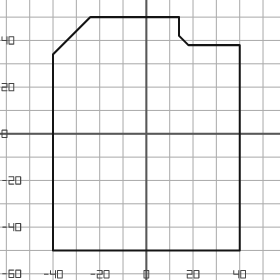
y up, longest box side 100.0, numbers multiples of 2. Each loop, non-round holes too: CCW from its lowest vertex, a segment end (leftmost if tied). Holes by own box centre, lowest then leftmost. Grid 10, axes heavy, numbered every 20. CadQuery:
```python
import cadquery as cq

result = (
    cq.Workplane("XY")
    .moveTo(-40.0, -50.0)
    .lineTo(40.0, -50.0)
    .lineTo(40.0, 38.0)
    .lineTo(18.0, 38.0)
    .lineTo(14.0, 42.0)
    .lineTo(14.0, 50.0)
    .lineTo(-24.0, 50.0)
    .lineTo(-40.0, 34.0)
    .close()
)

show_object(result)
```